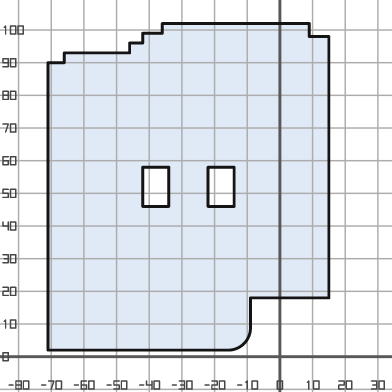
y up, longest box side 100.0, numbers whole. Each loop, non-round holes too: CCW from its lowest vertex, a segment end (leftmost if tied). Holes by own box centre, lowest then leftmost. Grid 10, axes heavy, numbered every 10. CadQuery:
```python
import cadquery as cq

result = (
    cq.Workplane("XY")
    .moveTo(-71.0, 2.0)
    .lineTo(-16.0, 2.0)
    .threePointArc((-11.0, 4.0), (-9.0, 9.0))
    .lineTo(-9.0, 18.0)
    .lineTo(15.0, 18.0)
    .lineTo(15.0, 98.0)
    .lineTo(9.0, 98.0)
    .lineTo(9.0, 102.0)
    .lineTo(-36.0, 102.0)
    .lineTo(-36.0, 99.0)
    .lineTo(-42.0, 99.0)
    .lineTo(-42.0, 96.0)
    .lineTo(-46.0, 96.0)
    .lineTo(-46.0, 93.0)
    .lineTo(-66.0, 93.0)
    .lineTo(-66.0, 90.0)
    .lineTo(-71.0, 90.0)
    .close()
    .moveTo(-42.0, 46.0)
    .lineTo(-34.0, 46.0)
    .lineTo(-34.0, 58.0)
    .lineTo(-42.0, 58.0)
    .close()
    .moveTo(-22.0, 46.0)
    .lineTo(-14.0, 46.0)
    .lineTo(-14.0, 58.0)
    .lineTo(-22.0, 58.0)
    .close()
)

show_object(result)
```